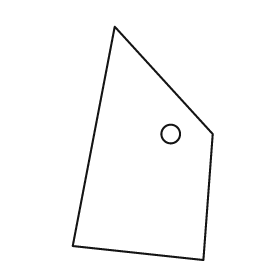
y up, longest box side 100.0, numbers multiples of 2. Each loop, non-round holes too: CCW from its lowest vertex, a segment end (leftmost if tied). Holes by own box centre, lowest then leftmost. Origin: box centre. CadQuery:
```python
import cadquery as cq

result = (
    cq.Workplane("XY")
    .moveTo(26.0, -50.0)
    .lineTo(30.0, 4.0)
    .lineTo(-12.0, 50.0)
    .lineTo(-30.0, -44.0)
    .close()
    .moveTo(12.0, 4.0)
    .circle(4.0)
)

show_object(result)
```